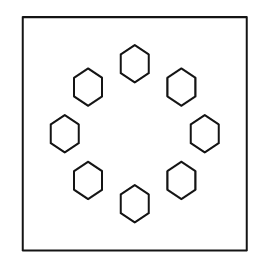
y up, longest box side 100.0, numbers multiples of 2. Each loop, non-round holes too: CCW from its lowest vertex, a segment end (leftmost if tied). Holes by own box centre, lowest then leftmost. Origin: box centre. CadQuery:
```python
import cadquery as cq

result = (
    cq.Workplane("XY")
    .moveTo(-48.0, -50.0)
    .lineTo(48.0, -50.0)
    .lineTo(48.0, 50.0)
    .lineTo(-48.0, 50.0)
    .close()
    .moveTo(0.0, -38.0)
    .lineTo(6.0, -34.0)
    .lineTo(6.0, -26.0)
    .lineTo(0.0, -22.0)
    .lineTo(-6.0, -26.0)
    .lineTo(-6.0, -34.0)
    .close()
    .moveTo(-20.0, -28.0)
    .lineTo(-14.0, -24.0)
    .lineTo(-14.0, -16.0)
    .lineTo(-20.0, -12.0)
    .lineTo(-26.0, -16.0)
    .lineTo(-26.0, -24.0)
    .close()
    .moveTo(20.0, -28.0)
    .lineTo(26.0, -24.0)
    .lineTo(26.0, -16.0)
    .lineTo(20.0, -12.0)
    .lineTo(14.0, -16.0)
    .lineTo(14.0, -24.0)
    .close()
    .moveTo(-30.0, -8.0)
    .lineTo(-24.0, -4.0)
    .lineTo(-24.0, 4.0)
    .lineTo(-30.0, 8.0)
    .lineTo(-36.0, 4.0)
    .lineTo(-36.0, -4.0)
    .close()
    .moveTo(30.0, -8.0)
    .lineTo(36.0, -4.0)
    .lineTo(36.0, 4.0)
    .lineTo(30.0, 8.0)
    .lineTo(24.0, 4.0)
    .lineTo(24.0, -4.0)
    .close()
    .moveTo(-20.0, 12.0)
    .lineTo(-14.0, 16.0)
    .lineTo(-14.0, 24.0)
    .lineTo(-20.0, 28.0)
    .lineTo(-26.0, 24.0)
    .lineTo(-26.0, 16.0)
    .close()
    .moveTo(20.0, 12.0)
    .lineTo(26.0, 16.0)
    .lineTo(26.0, 24.0)
    .lineTo(20.0, 28.0)
    .lineTo(14.0, 24.0)
    .lineTo(14.0, 16.0)
    .close()
    .moveTo(0.0, 22.0)
    .lineTo(6.0, 26.0)
    .lineTo(6.0, 34.0)
    .lineTo(0.0, 38.0)
    .lineTo(-6.0, 34.0)
    .lineTo(-6.0, 26.0)
    .close()
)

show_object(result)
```